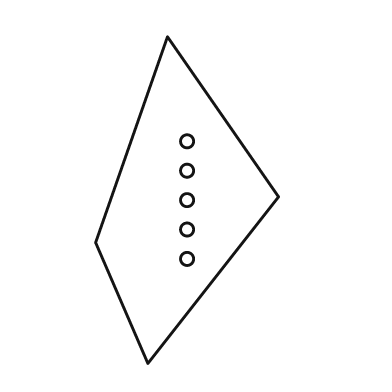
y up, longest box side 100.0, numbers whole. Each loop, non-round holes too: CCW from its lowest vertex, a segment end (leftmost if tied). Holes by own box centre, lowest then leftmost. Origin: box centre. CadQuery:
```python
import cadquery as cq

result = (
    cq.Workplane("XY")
    .moveTo(-12.0, -50.0)
    .lineTo(28.0, 1.0)
    .lineTo(-6.0, 50.0)
    .lineTo(-28.0, -13.0)
    .close()
    .moveTo(0.0, -18.0)
    .circle(2.0)
    .moveTo(0.0, -9.0)
    .circle(2.0)
    .moveTo(0.0, 0.0)
    .circle(2.0)
    .moveTo(0.0, 9.0)
    .circle(2.0)
    .moveTo(0.0, 18.0)
    .circle(2.0)
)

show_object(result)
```